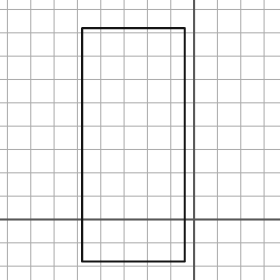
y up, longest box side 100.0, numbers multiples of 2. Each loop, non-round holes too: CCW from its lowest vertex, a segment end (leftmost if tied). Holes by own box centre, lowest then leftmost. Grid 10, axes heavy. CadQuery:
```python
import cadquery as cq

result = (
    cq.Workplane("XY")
    .moveTo(-48.0, -18.0)
    .lineTo(-4.0, -18.0)
    .lineTo(-4.0, 82.0)
    .lineTo(-48.0, 82.0)
    .close()
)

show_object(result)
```